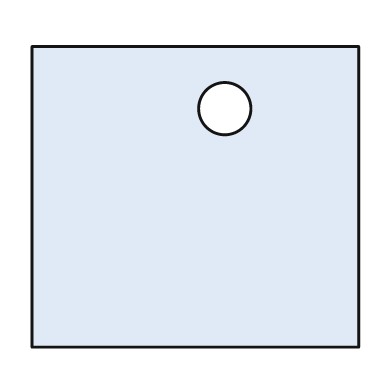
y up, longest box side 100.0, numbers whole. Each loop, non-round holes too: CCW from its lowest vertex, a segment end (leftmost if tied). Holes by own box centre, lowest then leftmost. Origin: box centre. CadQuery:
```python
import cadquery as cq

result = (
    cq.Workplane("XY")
    .moveTo(-50.0, -46.0)
    .lineTo(50.0, -46.0)
    .lineTo(50.0, 46.0)
    .lineTo(-50.0, 46.0)
    .close()
    .moveTo(9.0, 27.0)
    .circle(8.0)
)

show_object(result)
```